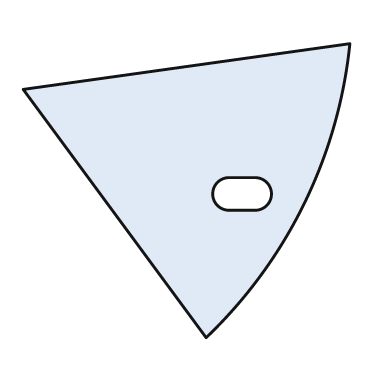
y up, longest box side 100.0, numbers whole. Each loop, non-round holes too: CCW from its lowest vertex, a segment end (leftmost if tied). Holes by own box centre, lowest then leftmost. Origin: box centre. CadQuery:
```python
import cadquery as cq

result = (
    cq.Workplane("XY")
    .moveTo(6.0, -45.0)
    .threePointArc((36.0, -4.0), (50.0, 45.0))
    .lineTo(-50.0, 31.0)
    .close()
    .moveTo(13.0, -6.0)
    .lineTo(21.0, -6.0)
    .threePointArc((26.0, -1.0), (21.0, 4.0))
    .lineTo(13.0, 4.0)
    .threePointArc((8.0, -1.0), (13.0, -6.0))
    .close()
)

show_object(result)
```